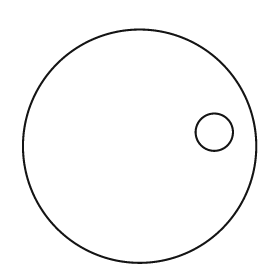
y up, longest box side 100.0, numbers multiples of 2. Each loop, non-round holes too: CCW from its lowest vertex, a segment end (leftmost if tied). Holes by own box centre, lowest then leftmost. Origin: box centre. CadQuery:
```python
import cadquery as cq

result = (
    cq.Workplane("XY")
    .moveTo(0.0, 0.0)
    .circle(50.0)
    .moveTo(32.0, 6.0)
    .circle(8.0)
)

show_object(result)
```